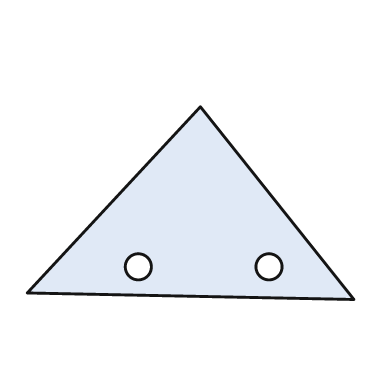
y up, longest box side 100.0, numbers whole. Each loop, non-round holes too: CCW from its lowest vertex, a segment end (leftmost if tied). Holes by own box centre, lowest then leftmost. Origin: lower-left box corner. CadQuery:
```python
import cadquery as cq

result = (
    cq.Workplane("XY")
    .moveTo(100.0, 0.0)
    .lineTo(53.0, 59.0)
    .lineTo(0.0, 2.0)
    .close()
    .moveTo(34.0, 10.0)
    .circle(4.0)
    .moveTo(74.0, 10.0)
    .circle(4.0)
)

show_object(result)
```